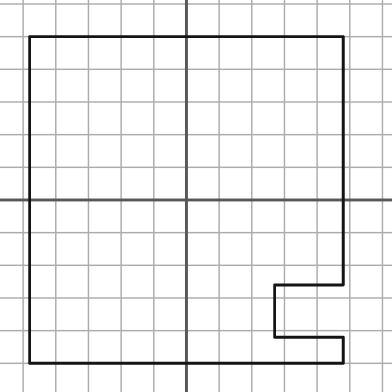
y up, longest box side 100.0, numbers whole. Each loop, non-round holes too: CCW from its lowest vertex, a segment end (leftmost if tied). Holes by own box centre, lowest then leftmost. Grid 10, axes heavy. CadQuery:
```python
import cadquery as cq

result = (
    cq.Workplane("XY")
    .moveTo(-48.0, -50.0)
    .lineTo(48.0, -50.0)
    .lineTo(48.0, -42.0)
    .lineTo(27.0, -42.0)
    .lineTo(27.0, -26.0)
    .lineTo(48.0, -26.0)
    .lineTo(48.0, 50.0)
    .lineTo(-48.0, 50.0)
    .close()
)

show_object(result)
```